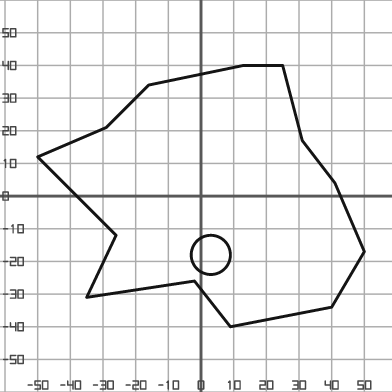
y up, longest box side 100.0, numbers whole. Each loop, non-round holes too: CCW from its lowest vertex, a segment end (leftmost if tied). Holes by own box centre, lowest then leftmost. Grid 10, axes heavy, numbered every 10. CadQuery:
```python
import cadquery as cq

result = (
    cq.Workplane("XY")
    .moveTo(9.0, -40.0)
    .lineTo(40.0, -34.0)
    .lineTo(50.0, -17.0)
    .lineTo(41.0, 4.0)
    .lineTo(31.0, 17.0)
    .lineTo(25.0, 40.0)
    .lineTo(13.0, 40.0)
    .lineTo(-16.0, 34.0)
    .lineTo(-29.0, 21.0)
    .lineTo(-50.0, 12.0)
    .lineTo(-26.0, -12.0)
    .lineTo(-35.0, -31.0)
    .lineTo(-2.0, -26.0)
    .close()
    .moveTo(3.0, -18.0)
    .circle(6.0)
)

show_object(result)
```